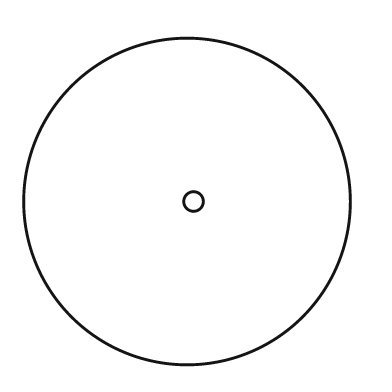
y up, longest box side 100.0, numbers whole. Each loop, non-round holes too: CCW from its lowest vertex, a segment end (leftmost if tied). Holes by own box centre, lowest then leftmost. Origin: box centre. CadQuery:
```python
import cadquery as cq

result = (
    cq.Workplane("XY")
    .moveTo(0.0, 0.0)
    .circle(50.0)
    .moveTo(2.0, 0.0)
    .circle(3.0)
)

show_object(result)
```